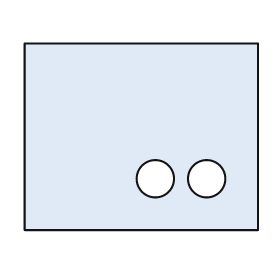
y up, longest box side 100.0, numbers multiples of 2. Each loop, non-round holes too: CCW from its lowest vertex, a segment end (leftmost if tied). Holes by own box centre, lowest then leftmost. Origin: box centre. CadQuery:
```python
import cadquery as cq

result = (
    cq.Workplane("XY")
    .moveTo(-50.0, -40.0)
    .lineTo(50.0, -40.0)
    .lineTo(50.0, 40.0)
    .lineTo(-50.0, 40.0)
    .close()
    .moveTo(6.0, -18.0)
    .circle(8.0)
    .moveTo(28.0, -18.0)
    .circle(8.0)
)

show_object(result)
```